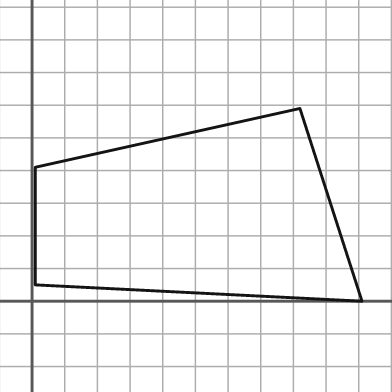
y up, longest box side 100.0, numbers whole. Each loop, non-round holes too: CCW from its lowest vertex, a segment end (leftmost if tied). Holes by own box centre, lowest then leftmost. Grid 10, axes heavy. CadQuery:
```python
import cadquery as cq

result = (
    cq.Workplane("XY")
    .moveTo(101.0, 0.0)
    .lineTo(82.0, 59.0)
    .lineTo(1.0, 41.0)
    .lineTo(1.0, 5.0)
    .close()
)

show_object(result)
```